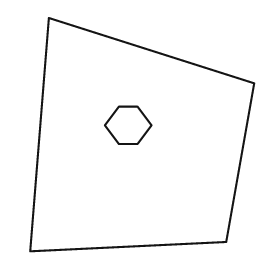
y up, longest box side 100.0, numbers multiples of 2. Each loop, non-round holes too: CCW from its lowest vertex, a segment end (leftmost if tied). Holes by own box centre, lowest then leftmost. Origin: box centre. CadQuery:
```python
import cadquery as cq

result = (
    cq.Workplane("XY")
    .moveTo(-48.0, -50.0)
    .lineTo(36.0, -46.0)
    .lineTo(48.0, 22.0)
    .lineTo(-40.0, 50.0)
    .close()
    .moveTo(-10.0, -4.0)
    .lineTo(-2.0, -4.0)
    .lineTo(4.0, 4.0)
    .lineTo(-2.0, 12.0)
    .lineTo(-10.0, 12.0)
    .lineTo(-16.0, 4.0)
    .close()
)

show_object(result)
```